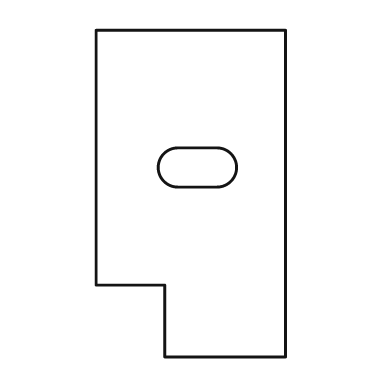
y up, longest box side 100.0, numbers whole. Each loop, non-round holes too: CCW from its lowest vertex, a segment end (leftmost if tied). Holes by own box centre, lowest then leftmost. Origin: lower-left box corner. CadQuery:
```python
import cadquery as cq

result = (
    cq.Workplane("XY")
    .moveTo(21.0, 0.0)
    .lineTo(58.0, 0.0)
    .lineTo(58.0, 100.0)
    .lineTo(0.0, 100.0)
    .lineTo(0.0, 22.0)
    .lineTo(21.0, 22.0)
    .close()
    .moveTo(25.0, 52.0)
    .lineTo(37.0, 52.0)
    .threePointArc((43.0, 58.0), (37.0, 64.0))
    .lineTo(25.0, 64.0)
    .threePointArc((19.0, 58.0), (25.0, 52.0))
    .close()
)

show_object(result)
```